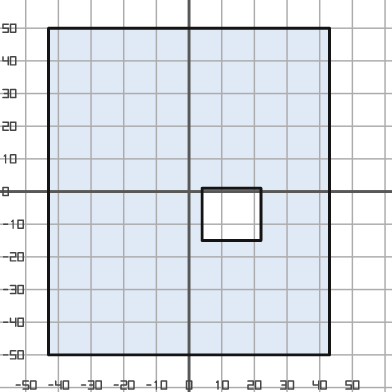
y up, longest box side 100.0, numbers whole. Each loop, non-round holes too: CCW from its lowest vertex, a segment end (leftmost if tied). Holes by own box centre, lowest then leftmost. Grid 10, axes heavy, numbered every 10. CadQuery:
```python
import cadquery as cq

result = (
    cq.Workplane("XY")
    .moveTo(-43.0, -50.0)
    .lineTo(43.0, -50.0)
    .lineTo(43.0, 50.0)
    .lineTo(-43.0, 50.0)
    .close()
    .moveTo(4.0, -15.0)
    .lineTo(22.0, -15.0)
    .lineTo(22.0, 1.0)
    .lineTo(4.0, 1.0)
    .close()
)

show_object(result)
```